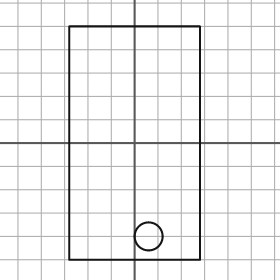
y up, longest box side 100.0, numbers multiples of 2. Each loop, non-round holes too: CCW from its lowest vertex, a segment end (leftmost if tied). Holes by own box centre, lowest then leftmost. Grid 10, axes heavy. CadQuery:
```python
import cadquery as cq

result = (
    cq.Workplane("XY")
    .moveTo(-28.0, -50.0)
    .lineTo(28.0, -50.0)
    .lineTo(28.0, 50.0)
    .lineTo(-28.0, 50.0)
    .close()
    .moveTo(6.0, -40.0)
    .circle(6.0)
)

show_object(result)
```